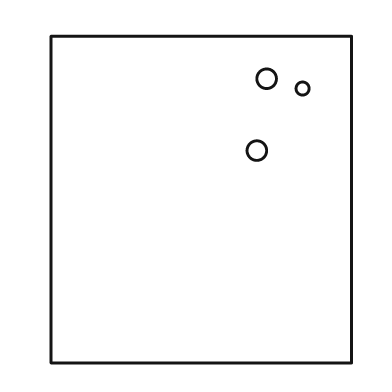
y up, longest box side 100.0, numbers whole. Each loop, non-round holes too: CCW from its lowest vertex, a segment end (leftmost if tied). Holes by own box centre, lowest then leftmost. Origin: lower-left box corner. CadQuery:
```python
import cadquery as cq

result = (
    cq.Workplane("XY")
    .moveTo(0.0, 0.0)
    .lineTo(92.0, 0.0)
    .lineTo(92.0, 100.0)
    .lineTo(0.0, 100.0)
    .close()
    .moveTo(63.0, 65.0)
    .circle(3.0)
    .moveTo(77.0, 84.0)
    .circle(2.0)
    .moveTo(66.0, 87.0)
    .circle(3.0)
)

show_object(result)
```